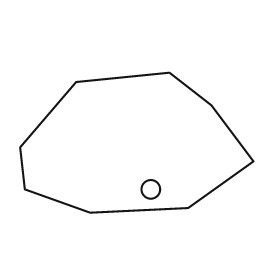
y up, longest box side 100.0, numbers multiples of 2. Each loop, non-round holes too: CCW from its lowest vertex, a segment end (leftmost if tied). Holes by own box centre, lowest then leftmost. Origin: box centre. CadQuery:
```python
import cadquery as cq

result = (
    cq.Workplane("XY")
    .moveTo(-20.0, -30.0)
    .lineTo(22.0, -28.0)
    .lineTo(50.0, -8.0)
    .lineTo(32.0, 16.0)
    .lineTo(14.0, 30.0)
    .lineTo(-26.0, 26.0)
    .lineTo(-50.0, -2.0)
    .lineTo(-48.0, -20.0)
    .close()
    .moveTo(6.0, -20.0)
    .circle(4.0)
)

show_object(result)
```